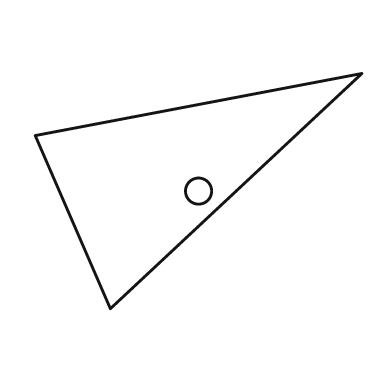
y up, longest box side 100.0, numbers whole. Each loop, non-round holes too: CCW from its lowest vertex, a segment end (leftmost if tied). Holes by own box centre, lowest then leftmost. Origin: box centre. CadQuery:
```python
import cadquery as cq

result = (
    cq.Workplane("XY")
    .moveTo(-27.0, -36.0)
    .lineTo(50.0, 36.0)
    .lineTo(-50.0, 17.0)
    .close()
    .moveTo(0.0, 0.0)
    .circle(4.0)
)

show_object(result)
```